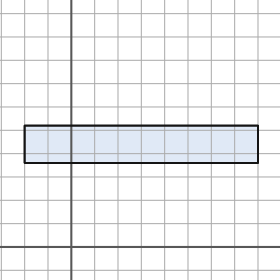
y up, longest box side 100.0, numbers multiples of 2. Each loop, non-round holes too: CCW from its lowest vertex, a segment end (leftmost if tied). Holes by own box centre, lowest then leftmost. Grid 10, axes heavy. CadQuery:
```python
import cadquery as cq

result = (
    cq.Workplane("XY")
    .moveTo(-20.0, 36.0)
    .lineTo(80.0, 36.0)
    .lineTo(80.0, 52.0)
    .lineTo(-20.0, 52.0)
    .close()
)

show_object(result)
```